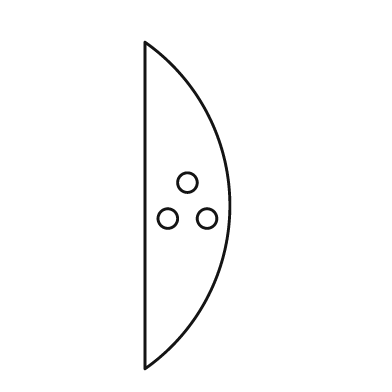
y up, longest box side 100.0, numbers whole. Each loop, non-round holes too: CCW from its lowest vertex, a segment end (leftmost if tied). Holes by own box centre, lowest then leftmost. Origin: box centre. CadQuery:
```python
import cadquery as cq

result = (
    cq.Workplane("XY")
    .moveTo(-13.0, -50.0)
    .threePointArc((13.0, 0.0), (-13.0, 50.0))
    .close()
    .moveTo(-6.0, -4.0)
    .circle(3.0)
    .moveTo(6.0, -4.0)
    .circle(3.0)
    .moveTo(0.0, 7.0)
    .circle(3.0)
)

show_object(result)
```